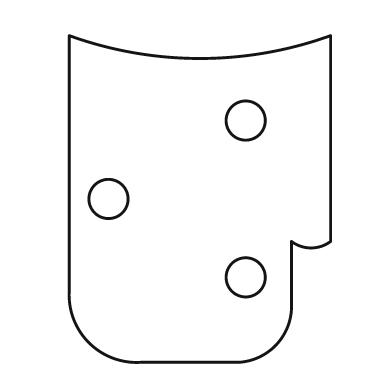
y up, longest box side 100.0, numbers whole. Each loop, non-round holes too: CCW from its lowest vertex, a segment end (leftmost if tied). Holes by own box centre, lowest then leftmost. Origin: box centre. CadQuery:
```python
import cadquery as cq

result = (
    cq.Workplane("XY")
    .moveTo(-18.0, -50.0)
    .lineTo(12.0, -50.0)
    .threePointArc((23.0, -45.0), (28.0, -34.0))
    .lineTo(28.0, -13.0)
    .threePointArc((34.0, -15.0), (40.0, -13.0))
    .lineTo(40.0, 50.0)
    .threePointArc((0.0, 43.0), (-40.0, 50.0))
    .lineTo(-40.0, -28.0)
    .threePointArc((-34.0, -44.0), (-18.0, -50.0))
    .close()
    .moveTo(14.0, -24.0)
    .circle(6.0)
    .moveTo(-28.0, 0.0)
    .circle(6.0)
    .moveTo(14.0, 24.0)
    .circle(6.0)
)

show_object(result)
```